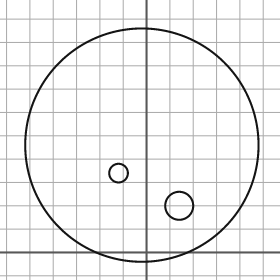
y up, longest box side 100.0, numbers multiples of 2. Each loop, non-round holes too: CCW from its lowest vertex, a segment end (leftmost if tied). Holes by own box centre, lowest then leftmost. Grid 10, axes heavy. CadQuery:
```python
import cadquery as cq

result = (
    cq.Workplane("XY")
    .moveTo(-2.0, 46.0)
    .circle(50.0)
    .moveTo(14.0, 20.0)
    .circle(6.0)
    .moveTo(-12.0, 34.0)
    .circle(4.0)
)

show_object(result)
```